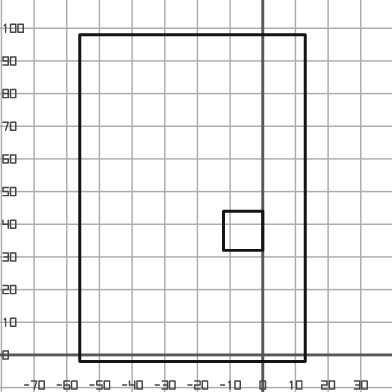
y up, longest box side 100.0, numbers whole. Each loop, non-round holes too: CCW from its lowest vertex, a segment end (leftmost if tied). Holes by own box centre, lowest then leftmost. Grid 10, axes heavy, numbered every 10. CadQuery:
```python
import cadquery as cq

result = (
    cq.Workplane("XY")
    .moveTo(-56.0, -2.0)
    .lineTo(13.0, -2.0)
    .lineTo(13.0, 98.0)
    .lineTo(-56.0, 98.0)
    .close()
    .moveTo(-12.0, 32.0)
    .lineTo(0.0, 32.0)
    .lineTo(0.0, 44.0)
    .lineTo(-12.0, 44.0)
    .close()
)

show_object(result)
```